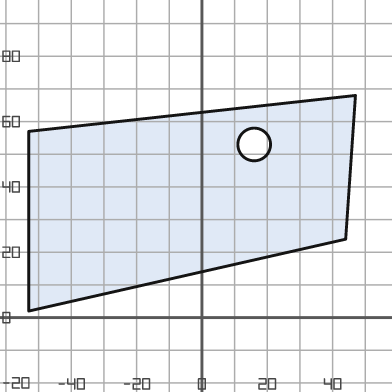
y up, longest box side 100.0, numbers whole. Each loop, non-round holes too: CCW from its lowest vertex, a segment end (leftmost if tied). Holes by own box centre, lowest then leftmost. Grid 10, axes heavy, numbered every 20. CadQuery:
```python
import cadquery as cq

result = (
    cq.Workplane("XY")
    .moveTo(-53.0, 2.0)
    .lineTo(44.0, 24.0)
    .lineTo(47.0, 68.0)
    .lineTo(-53.0, 57.0)
    .close()
    .moveTo(16.0, 53.0)
    .circle(5.0)
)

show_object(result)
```